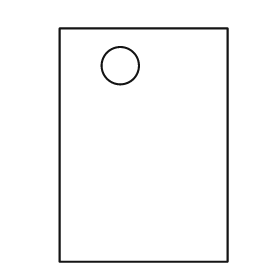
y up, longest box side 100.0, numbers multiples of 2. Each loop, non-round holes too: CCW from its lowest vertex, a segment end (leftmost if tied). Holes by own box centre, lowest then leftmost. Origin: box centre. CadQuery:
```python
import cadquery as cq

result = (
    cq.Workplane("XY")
    .moveTo(-36.0, -50.0)
    .lineTo(36.0, -50.0)
    .lineTo(36.0, 50.0)
    .lineTo(-36.0, 50.0)
    .close()
    .moveTo(-10.0, 34.0)
    .circle(8.0)
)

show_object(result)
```